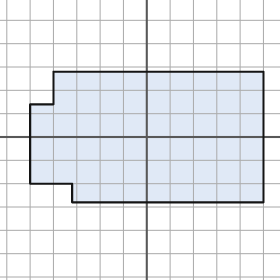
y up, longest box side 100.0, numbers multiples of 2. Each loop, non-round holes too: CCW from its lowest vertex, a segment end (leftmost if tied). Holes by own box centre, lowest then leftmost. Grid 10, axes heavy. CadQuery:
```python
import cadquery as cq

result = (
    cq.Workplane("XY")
    .moveTo(-32.0, -28.0)
    .lineTo(50.0, -28.0)
    .lineTo(50.0, 28.0)
    .lineTo(-40.0, 28.0)
    .lineTo(-40.0, 14.0)
    .lineTo(-50.0, 14.0)
    .lineTo(-50.0, -20.0)
    .lineTo(-32.0, -20.0)
    .close()
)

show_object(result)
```